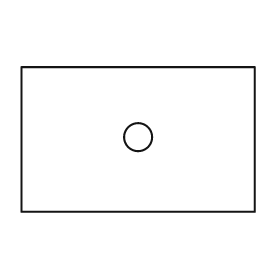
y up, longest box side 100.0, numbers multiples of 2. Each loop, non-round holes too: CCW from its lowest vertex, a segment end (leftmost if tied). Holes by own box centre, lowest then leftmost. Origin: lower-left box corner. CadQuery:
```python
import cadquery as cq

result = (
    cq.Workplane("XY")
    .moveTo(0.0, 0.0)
    .lineTo(100.0, 0.0)
    .lineTo(100.0, 62.0)
    .lineTo(0.0, 62.0)
    .close()
    .moveTo(50.0, 32.0)
    .circle(6.0)
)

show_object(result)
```